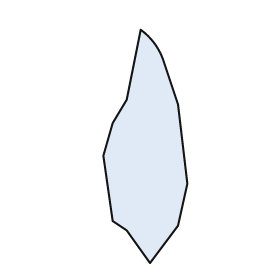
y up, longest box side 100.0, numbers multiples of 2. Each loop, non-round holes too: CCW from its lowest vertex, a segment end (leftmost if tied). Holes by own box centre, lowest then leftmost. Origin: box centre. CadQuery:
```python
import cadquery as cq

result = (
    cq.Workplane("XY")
    .moveTo(2.0, -50.0)
    .lineTo(14.0, -34.0)
    .lineTo(18.0, -16.0)
    .lineTo(14.0, 18.0)
    .lineTo(8.0, 36.0)
    .threePointArc((4.0, 44.0), (-2.0, 50.0))
    .lineTo(-8.0, 20.0)
    .lineTo(-14.0, 10.0)
    .lineTo(-18.0, -4.0)
    .lineTo(-14.0, -32.0)
    .lineTo(-8.0, -36.0)
    .close()
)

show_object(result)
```